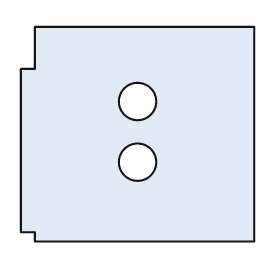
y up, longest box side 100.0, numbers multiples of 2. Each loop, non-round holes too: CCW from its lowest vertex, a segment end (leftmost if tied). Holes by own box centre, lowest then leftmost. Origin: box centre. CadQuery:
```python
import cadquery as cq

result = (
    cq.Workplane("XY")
    .moveTo(-44.0, -46.0)
    .lineTo(50.0, -46.0)
    .lineTo(50.0, 46.0)
    .lineTo(-44.0, 46.0)
    .lineTo(-44.0, 28.0)
    .lineTo(-50.0, 28.0)
    .lineTo(-50.0, -42.0)
    .lineTo(-44.0, -42.0)
    .close()
    .moveTo(0.0, -12.0)
    .circle(8.0)
    .moveTo(0.0, 14.0)
    .circle(8.0)
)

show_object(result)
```